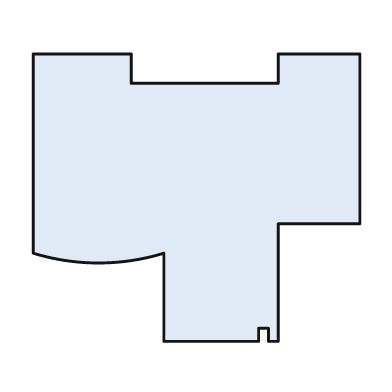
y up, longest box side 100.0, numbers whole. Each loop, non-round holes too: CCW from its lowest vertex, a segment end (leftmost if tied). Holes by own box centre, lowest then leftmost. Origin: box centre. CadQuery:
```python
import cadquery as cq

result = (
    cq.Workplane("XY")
    .moveTo(-10.0, -44.0)
    .lineTo(19.0, -44.0)
    .lineTo(19.0, -40.0)
    .lineTo(22.0, -40.0)
    .lineTo(22.0, -44.0)
    .lineTo(25.0, -44.0)
    .lineTo(25.0, -8.0)
    .lineTo(50.0, -8.0)
    .lineTo(50.0, 44.0)
    .lineTo(25.0, 44.0)
    .lineTo(25.0, 35.0)
    .lineTo(-20.0, 35.0)
    .lineTo(-20.0, 44.0)
    .lineTo(-50.0, 44.0)
    .lineTo(-50.0, -17.0)
    .threePointArc((-30.0, -20.0), (-10.0, -17.0))
    .close()
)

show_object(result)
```